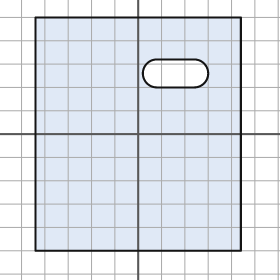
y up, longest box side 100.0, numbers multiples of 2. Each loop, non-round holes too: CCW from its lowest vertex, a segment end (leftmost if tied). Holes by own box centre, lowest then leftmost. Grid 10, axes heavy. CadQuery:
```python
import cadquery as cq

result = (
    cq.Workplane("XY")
    .moveTo(-44.0, -50.0)
    .lineTo(44.0, -50.0)
    .lineTo(44.0, 50.0)
    .lineTo(-44.0, 50.0)
    .close()
    .moveTo(8.0, 20.0)
    .lineTo(24.0, 20.0)
    .threePointArc((30.0, 26.0), (24.0, 32.0))
    .lineTo(8.0, 32.0)
    .threePointArc((2.0, 26.0), (8.0, 20.0))
    .close()
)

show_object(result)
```